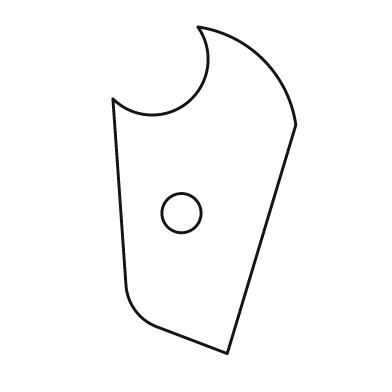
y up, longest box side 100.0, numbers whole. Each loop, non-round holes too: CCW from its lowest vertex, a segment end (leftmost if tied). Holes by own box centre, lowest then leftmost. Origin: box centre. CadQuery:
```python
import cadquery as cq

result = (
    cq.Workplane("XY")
    .moveTo(7.0, -50.0)
    .lineTo(28.0, 20.0)
    .threePointArc((18.0, 40.0), (-2.0, 50.0))
    .threePointArc((-5.0, 27.0), (-28.0, 28.0))
    .lineTo(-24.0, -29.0)
    .threePointArc((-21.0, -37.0), (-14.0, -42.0))
    .close()
    .moveTo(-7.0, -7.0)
    .circle(6.0)
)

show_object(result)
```